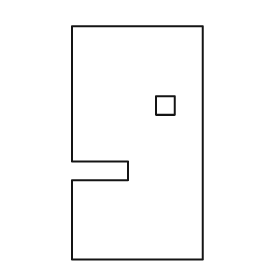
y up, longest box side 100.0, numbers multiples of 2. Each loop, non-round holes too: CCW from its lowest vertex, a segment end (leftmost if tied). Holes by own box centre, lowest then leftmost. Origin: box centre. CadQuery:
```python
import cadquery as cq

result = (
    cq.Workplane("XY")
    .moveTo(-28.0, -50.0)
    .lineTo(28.0, -50.0)
    .lineTo(28.0, 50.0)
    .lineTo(-28.0, 50.0)
    .lineTo(-28.0, -8.0)
    .lineTo(-4.0, -8.0)
    .lineTo(-4.0, -16.0)
    .lineTo(-28.0, -16.0)
    .close()
    .moveTo(8.0, 12.0)
    .lineTo(16.0, 12.0)
    .lineTo(16.0, 20.0)
    .lineTo(8.0, 20.0)
    .close()
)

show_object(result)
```